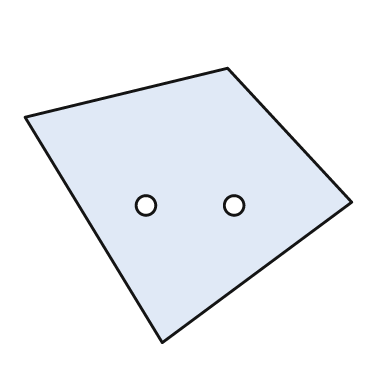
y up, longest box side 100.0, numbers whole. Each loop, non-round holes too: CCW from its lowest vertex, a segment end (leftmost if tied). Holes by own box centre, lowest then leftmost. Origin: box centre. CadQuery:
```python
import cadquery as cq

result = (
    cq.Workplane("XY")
    .moveTo(-8.0, -42.0)
    .lineTo(50.0, 1.0)
    .lineTo(12.0, 42.0)
    .lineTo(-50.0, 27.0)
    .close()
    .moveTo(-13.0, 0.0)
    .circle(3.0)
    .moveTo(14.0, 0.0)
    .circle(3.0)
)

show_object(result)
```